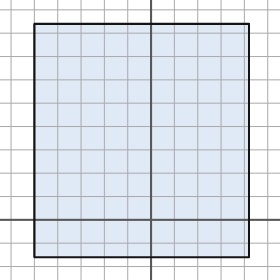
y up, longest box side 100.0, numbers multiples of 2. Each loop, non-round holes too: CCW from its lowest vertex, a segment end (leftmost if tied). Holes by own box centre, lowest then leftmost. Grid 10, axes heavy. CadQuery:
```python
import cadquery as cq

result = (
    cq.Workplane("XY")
    .moveTo(-50.0, -16.0)
    .lineTo(42.0, -16.0)
    .lineTo(42.0, 84.0)
    .lineTo(-50.0, 84.0)
    .close()
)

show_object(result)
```